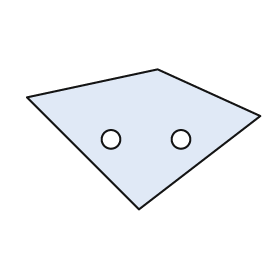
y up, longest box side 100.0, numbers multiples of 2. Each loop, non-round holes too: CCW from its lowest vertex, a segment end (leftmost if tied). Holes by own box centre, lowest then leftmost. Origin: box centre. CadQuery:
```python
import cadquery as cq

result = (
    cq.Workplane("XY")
    .moveTo(-2.0, -30.0)
    .lineTo(50.0, 10.0)
    .lineTo(6.0, 30.0)
    .lineTo(-50.0, 18.0)
    .close()
    .moveTo(-14.0, 0.0)
    .circle(4.0)
    .moveTo(16.0, 0.0)
    .circle(4.0)
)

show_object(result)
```